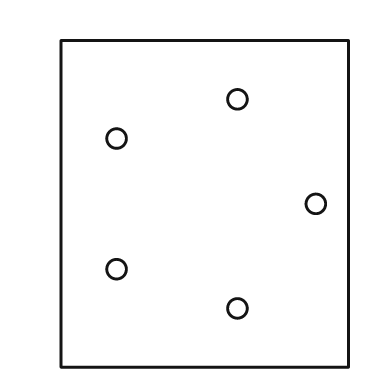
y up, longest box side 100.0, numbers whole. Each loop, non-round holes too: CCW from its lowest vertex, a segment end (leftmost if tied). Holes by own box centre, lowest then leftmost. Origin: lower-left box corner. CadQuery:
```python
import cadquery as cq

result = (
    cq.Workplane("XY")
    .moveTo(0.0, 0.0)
    .lineTo(88.0, 0.0)
    .lineTo(88.0, 100.0)
    .lineTo(0.0, 100.0)
    .close()
    .moveTo(54.0, 18.0)
    .circle(3.0)
    .moveTo(17.0, 30.0)
    .circle(3.0)
    .moveTo(78.0, 50.0)
    .circle(3.0)
    .moveTo(17.0, 70.0)
    .circle(3.0)
    .moveTo(54.0, 82.0)
    .circle(3.0)
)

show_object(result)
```